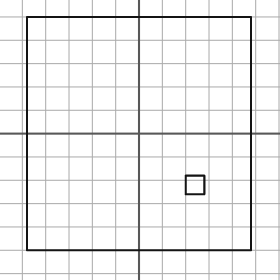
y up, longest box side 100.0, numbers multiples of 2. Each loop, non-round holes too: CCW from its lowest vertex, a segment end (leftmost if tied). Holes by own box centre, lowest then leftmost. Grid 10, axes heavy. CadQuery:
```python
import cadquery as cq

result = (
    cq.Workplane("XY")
    .moveTo(-48.0, -50.0)
    .lineTo(48.0, -50.0)
    .lineTo(48.0, 50.0)
    .lineTo(-48.0, 50.0)
    .close()
    .moveTo(20.0, -26.0)
    .lineTo(28.0, -26.0)
    .lineTo(28.0, -18.0)
    .lineTo(20.0, -18.0)
    .close()
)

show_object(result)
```